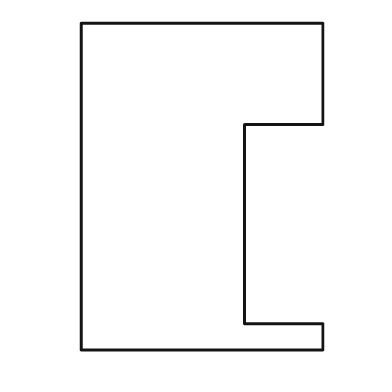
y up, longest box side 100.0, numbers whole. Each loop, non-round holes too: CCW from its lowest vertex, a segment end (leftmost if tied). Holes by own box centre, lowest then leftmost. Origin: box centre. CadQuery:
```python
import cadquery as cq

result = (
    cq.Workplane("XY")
    .moveTo(-37.0, -50.0)
    .lineTo(37.0, -50.0)
    .lineTo(37.0, -42.0)
    .lineTo(13.0, -42.0)
    .lineTo(13.0, 19.0)
    .lineTo(37.0, 19.0)
    .lineTo(37.0, 50.0)
    .lineTo(-37.0, 50.0)
    .close()
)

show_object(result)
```